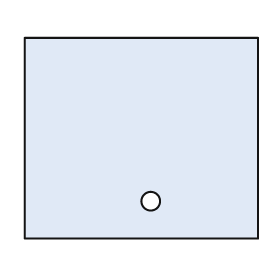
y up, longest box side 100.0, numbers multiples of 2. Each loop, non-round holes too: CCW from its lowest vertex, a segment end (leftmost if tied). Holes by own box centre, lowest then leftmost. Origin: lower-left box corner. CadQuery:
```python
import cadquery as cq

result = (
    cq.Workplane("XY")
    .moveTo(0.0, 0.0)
    .lineTo(100.0, 0.0)
    .lineTo(100.0, 86.0)
    .lineTo(0.0, 86.0)
    .close()
    .moveTo(54.0, 16.0)
    .circle(4.0)
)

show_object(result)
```